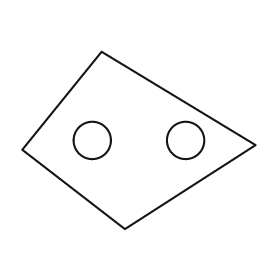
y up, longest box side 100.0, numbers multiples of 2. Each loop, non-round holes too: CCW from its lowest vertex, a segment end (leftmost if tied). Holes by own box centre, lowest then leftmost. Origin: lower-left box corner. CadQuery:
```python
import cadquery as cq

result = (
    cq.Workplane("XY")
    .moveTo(44.0, 0.0)
    .lineTo(100.0, 36.0)
    .lineTo(34.0, 76.0)
    .lineTo(0.0, 34.0)
    .close()
    .moveTo(30.0, 38.0)
    .circle(8.0)
    .moveTo(70.0, 38.0)
    .circle(8.0)
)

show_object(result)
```